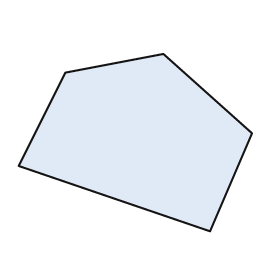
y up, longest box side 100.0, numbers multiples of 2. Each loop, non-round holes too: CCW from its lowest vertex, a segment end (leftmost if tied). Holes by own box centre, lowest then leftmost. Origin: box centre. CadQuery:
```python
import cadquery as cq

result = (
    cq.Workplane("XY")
    .moveTo(32.0, -38.0)
    .lineTo(50.0, 4.0)
    .lineTo(12.0, 38.0)
    .lineTo(-30.0, 30.0)
    .lineTo(-50.0, -10.0)
    .close()
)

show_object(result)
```